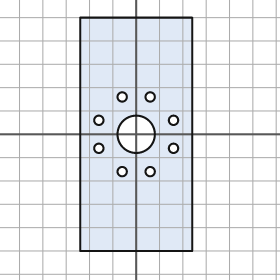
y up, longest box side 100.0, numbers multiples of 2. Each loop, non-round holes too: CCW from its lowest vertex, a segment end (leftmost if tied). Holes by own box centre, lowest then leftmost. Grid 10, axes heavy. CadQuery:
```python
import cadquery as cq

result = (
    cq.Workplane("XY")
    .moveTo(-24.0, -50.0)
    .lineTo(24.0, -50.0)
    .lineTo(24.0, 50.0)
    .lineTo(-24.0, 50.0)
    .close()
    .moveTo(-6.0, -16.0)
    .circle(2.0)
    .moveTo(6.0, -16.0)
    .circle(2.0)
    .moveTo(-16.0, -6.0)
    .circle(2.0)
    .moveTo(16.0, -6.0)
    .circle(2.0)
    .moveTo(0.0, 0.0)
    .circle(8.0)
    .moveTo(-16.0, 6.0)
    .circle(2.0)
    .moveTo(16.0, 6.0)
    .circle(2.0)
    .moveTo(-6.0, 16.0)
    .circle(2.0)
    .moveTo(6.0, 16.0)
    .circle(2.0)
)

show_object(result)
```